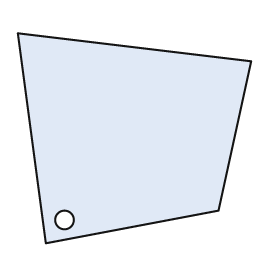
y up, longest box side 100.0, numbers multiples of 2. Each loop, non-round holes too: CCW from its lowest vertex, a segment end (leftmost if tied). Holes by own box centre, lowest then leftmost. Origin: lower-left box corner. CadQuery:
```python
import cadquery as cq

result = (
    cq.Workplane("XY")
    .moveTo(12.0, 0.0)
    .lineTo(86.0, 14.0)
    .lineTo(100.0, 78.0)
    .lineTo(0.0, 90.0)
    .close()
    .moveTo(20.0, 10.0)
    .circle(4.0)
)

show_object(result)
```